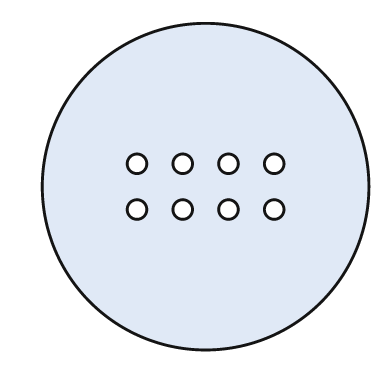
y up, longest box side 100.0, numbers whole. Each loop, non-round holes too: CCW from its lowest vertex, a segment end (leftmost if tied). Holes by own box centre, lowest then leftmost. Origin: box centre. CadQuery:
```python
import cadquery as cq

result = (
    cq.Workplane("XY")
    .moveTo(0.0, 0.0)
    .circle(50.0)
    .moveTo(-21.0, -7.0)
    .circle(3.0)
    .moveTo(-7.0, -7.0)
    .circle(3.0)
    .moveTo(7.0, -7.0)
    .circle(3.0)
    .moveTo(21.0, -7.0)
    .circle(3.0)
    .moveTo(-21.0, 7.0)
    .circle(3.0)
    .moveTo(-7.0, 7.0)
    .circle(3.0)
    .moveTo(7.0, 7.0)
    .circle(3.0)
    .moveTo(21.0, 7.0)
    .circle(3.0)
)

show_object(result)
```